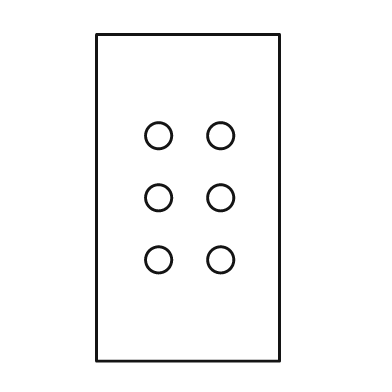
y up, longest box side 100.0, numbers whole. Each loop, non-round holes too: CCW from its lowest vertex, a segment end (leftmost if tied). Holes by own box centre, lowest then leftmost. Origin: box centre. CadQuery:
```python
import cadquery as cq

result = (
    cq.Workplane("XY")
    .moveTo(-28.0, -50.0)
    .lineTo(28.0, -50.0)
    .lineTo(28.0, 50.0)
    .lineTo(-28.0, 50.0)
    .close()
    .moveTo(-9.0, -19.0)
    .circle(4.0)
    .moveTo(10.0, -19.0)
    .circle(4.0)
    .moveTo(-9.0, 0.0)
    .circle(4.0)
    .moveTo(10.0, 0.0)
    .circle(4.0)
    .moveTo(-9.0, 19.0)
    .circle(4.0)
    .moveTo(10.0, 19.0)
    .circle(4.0)
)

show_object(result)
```